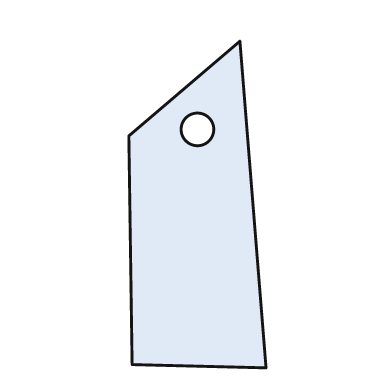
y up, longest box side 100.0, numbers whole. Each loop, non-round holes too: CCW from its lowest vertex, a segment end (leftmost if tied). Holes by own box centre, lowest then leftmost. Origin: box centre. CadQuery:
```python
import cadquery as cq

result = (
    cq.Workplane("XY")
    .moveTo(21.0, -50.0)
    .lineTo(13.0, 50.0)
    .lineTo(-21.0, 21.0)
    .lineTo(-20.0, -49.0)
    .close()
    .moveTo(0.0, 23.0)
    .circle(5.0)
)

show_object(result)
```